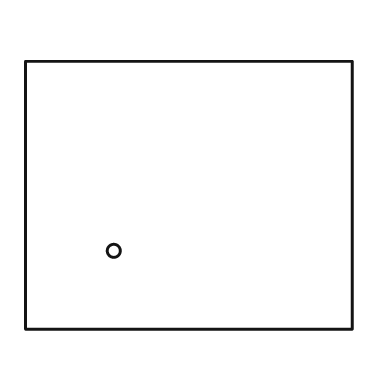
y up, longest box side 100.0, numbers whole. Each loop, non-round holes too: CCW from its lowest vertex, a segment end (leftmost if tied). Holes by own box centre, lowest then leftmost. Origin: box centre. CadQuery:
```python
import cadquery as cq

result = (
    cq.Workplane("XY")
    .moveTo(-50.0, -41.0)
    .lineTo(50.0, -41.0)
    .lineTo(50.0, 41.0)
    .lineTo(-50.0, 41.0)
    .close()
    .moveTo(-23.0, -17.0)
    .circle(2.0)
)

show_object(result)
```